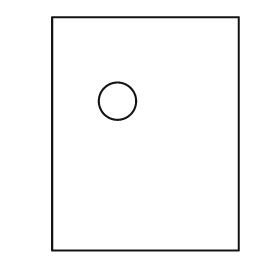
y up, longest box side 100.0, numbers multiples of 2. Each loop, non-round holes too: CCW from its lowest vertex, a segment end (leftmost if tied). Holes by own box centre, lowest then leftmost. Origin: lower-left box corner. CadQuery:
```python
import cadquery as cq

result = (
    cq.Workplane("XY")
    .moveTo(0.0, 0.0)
    .lineTo(80.0, 0.0)
    .lineTo(80.0, 100.0)
    .lineTo(0.0, 100.0)
    .close()
    .moveTo(28.0, 64.0)
    .circle(8.0)
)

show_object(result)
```